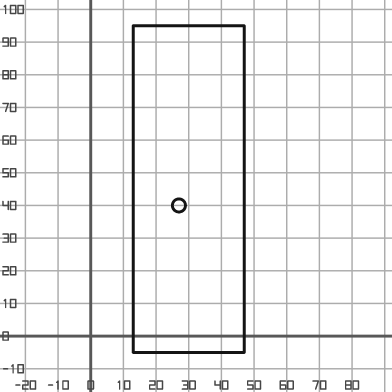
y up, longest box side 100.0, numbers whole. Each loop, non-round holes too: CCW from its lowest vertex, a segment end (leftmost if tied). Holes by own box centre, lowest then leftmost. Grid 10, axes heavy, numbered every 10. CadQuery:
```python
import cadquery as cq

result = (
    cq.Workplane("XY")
    .moveTo(13.0, -5.0)
    .lineTo(47.0, -5.0)
    .lineTo(47.0, 95.0)
    .lineTo(13.0, 95.0)
    .close()
    .moveTo(27.0, 40.0)
    .circle(2.0)
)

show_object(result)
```